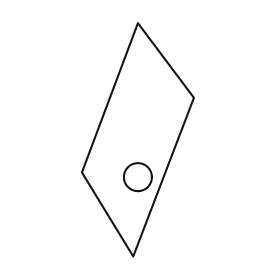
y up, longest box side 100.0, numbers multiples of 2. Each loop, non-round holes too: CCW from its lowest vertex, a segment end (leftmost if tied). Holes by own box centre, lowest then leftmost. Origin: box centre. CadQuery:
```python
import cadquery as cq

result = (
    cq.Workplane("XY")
    .moveTo(-2.0, -50.0)
    .lineTo(24.0, 18.0)
    .lineTo(0.0, 50.0)
    .lineTo(-24.0, -14.0)
    .close()
    .moveTo(0.0, -16.0)
    .circle(6.0)
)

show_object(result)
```